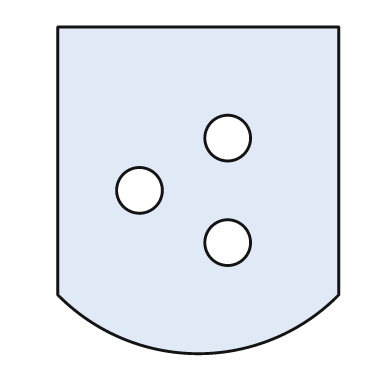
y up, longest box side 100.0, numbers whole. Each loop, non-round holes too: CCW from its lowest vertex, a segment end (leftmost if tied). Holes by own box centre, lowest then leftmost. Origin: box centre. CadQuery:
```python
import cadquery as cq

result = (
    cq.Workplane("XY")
    .moveTo(-43.0, -32.0)
    .threePointArc((0.0, -50.0), (43.0, -32.0))
    .lineTo(43.0, 50.0)
    .lineTo(-43.0, 50.0)
    .close()
    .moveTo(9.0, -16.0)
    .circle(7.0)
    .moveTo(-18.0, 0.0)
    .circle(7.0)
    .moveTo(9.0, 16.0)
    .circle(7.0)
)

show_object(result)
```